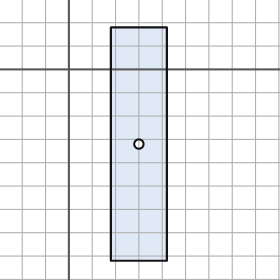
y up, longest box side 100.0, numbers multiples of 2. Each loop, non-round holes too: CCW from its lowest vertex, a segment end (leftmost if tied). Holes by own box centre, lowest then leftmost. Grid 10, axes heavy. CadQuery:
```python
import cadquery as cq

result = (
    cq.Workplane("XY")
    .moveTo(18.0, -82.0)
    .lineTo(42.0, -82.0)
    .lineTo(42.0, 18.0)
    .lineTo(18.0, 18.0)
    .close()
    .moveTo(30.0, -32.0)
    .circle(2.0)
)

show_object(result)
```